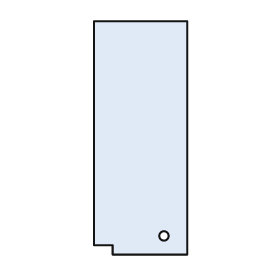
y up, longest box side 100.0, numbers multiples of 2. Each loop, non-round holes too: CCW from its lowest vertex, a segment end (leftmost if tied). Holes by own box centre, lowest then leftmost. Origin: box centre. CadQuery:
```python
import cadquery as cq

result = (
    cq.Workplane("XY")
    .moveTo(-12.0, -50.0)
    .lineTo(20.0, -50.0)
    .lineTo(20.0, 50.0)
    .lineTo(-20.0, 50.0)
    .lineTo(-20.0, -46.0)
    .lineTo(-12.0, -46.0)
    .close()
    .moveTo(10.0, -42.0)
    .circle(2.0)
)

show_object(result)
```